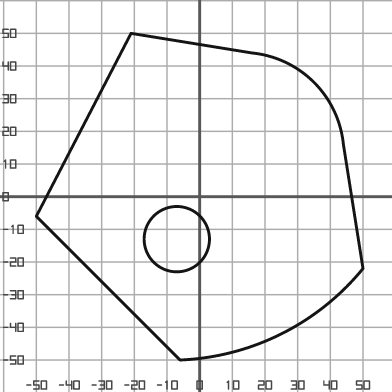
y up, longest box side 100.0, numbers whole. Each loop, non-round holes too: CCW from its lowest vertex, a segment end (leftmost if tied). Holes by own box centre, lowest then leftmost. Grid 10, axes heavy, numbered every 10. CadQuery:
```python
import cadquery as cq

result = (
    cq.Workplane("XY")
    .moveTo(-6.0, -50.0)
    .threePointArc((25.0, -42.0), (50.0, -22.0))
    .lineTo(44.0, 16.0)
    .threePointArc((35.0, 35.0), (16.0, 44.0))
    .lineTo(-21.0, 50.0)
    .lineTo(-50.0, -6.0)
    .close()
    .moveTo(-7.0, -13.0)
    .circle(10.0)
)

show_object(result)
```